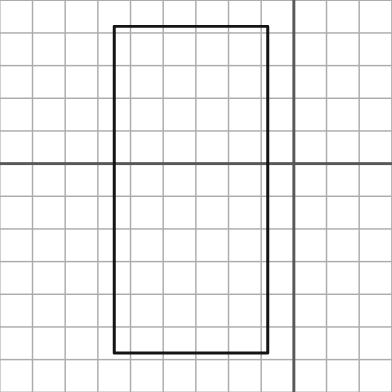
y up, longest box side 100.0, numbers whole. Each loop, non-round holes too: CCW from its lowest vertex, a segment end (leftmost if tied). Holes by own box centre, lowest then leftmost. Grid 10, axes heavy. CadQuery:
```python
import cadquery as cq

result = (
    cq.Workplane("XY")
    .moveTo(-55.0, -58.0)
    .lineTo(-8.0, -58.0)
    .lineTo(-8.0, 42.0)
    .lineTo(-55.0, 42.0)
    .close()
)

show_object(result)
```